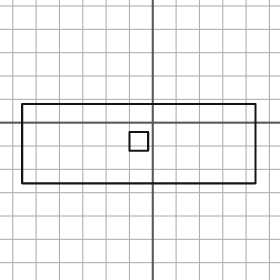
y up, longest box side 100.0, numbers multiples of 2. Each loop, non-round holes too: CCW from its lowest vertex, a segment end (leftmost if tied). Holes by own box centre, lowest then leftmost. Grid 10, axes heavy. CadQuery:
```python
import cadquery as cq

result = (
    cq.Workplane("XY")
    .moveTo(-56.0, -26.0)
    .lineTo(44.0, -26.0)
    .lineTo(44.0, 8.0)
    .lineTo(-56.0, 8.0)
    .close()
    .moveTo(-10.0, -12.0)
    .lineTo(-2.0, -12.0)
    .lineTo(-2.0, -4.0)
    .lineTo(-10.0, -4.0)
    .close()
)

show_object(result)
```